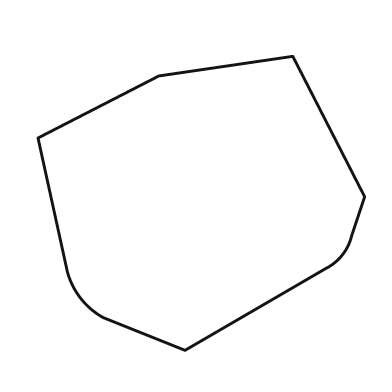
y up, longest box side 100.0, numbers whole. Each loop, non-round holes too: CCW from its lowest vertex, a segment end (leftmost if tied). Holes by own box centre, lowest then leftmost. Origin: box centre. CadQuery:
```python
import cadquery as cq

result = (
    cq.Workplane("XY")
    .moveTo(-5.0, -45.0)
    .lineTo(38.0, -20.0)
    .threePointArc((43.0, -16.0), (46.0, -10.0))
    .lineTo(50.0, 2.0)
    .lineTo(28.0, 45.0)
    .lineTo(-13.0, 39.0)
    .lineTo(-50.0, 20.0)
    .lineTo(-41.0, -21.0)
    .threePointArc((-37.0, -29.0), (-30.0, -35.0))
    .close()
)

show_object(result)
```